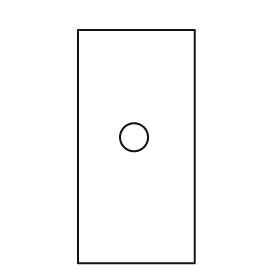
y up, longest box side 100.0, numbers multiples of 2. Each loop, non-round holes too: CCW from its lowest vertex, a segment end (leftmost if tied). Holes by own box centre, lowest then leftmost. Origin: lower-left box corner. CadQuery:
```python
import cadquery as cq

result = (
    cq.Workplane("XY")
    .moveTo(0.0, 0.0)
    .lineTo(50.0, 0.0)
    .lineTo(50.0, 100.0)
    .lineTo(0.0, 100.0)
    .close()
    .moveTo(24.0, 54.0)
    .circle(6.0)
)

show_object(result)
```